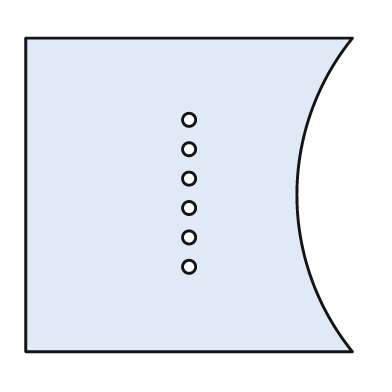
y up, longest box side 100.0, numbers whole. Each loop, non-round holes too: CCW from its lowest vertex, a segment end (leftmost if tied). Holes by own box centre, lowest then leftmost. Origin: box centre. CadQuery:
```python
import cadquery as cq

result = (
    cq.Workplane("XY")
    .moveTo(-50.0, -48.0)
    .lineTo(50.0, -48.0)
    .threePointArc((33.0, 0.0), (50.0, 48.0))
    .lineTo(-50.0, 48.0)
    .close()
    .moveTo(0.0, -22.0)
    .circle(2.0)
    .moveTo(0.0, -13.0)
    .circle(2.0)
    .moveTo(0.0, -4.0)
    .circle(2.0)
    .moveTo(0.0, 5.0)
    .circle(2.0)
    .moveTo(0.0, 14.0)
    .circle(2.0)
    .moveTo(0.0, 23.0)
    .circle(2.0)
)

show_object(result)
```